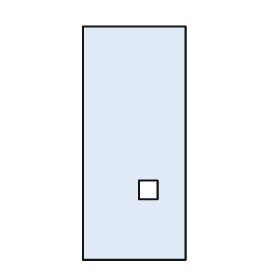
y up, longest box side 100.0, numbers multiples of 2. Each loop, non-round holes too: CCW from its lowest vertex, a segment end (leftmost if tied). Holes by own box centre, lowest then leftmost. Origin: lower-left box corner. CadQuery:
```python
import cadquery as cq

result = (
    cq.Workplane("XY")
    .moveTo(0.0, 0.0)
    .lineTo(44.0, 0.0)
    .lineTo(44.0, 100.0)
    .lineTo(0.0, 100.0)
    .close()
    .moveTo(24.0, 26.0)
    .lineTo(32.0, 26.0)
    .lineTo(32.0, 34.0)
    .lineTo(24.0, 34.0)
    .close()
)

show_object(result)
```